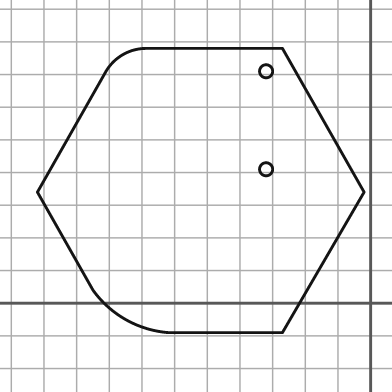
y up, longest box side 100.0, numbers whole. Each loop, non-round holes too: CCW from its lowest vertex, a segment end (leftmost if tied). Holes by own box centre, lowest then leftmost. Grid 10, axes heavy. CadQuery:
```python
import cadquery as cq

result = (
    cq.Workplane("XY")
    .moveTo(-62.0, -9.0)
    .lineTo(-27.0, -9.0)
    .lineTo(-2.0, 34.0)
    .lineTo(-27.0, 78.0)
    .lineTo(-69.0, 78.0)
    .threePointArc((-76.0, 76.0), (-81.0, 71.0))
    .lineTo(-102.0, 34.0)
    .lineTo(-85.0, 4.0)
    .threePointArc((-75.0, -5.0), (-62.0, -9.0))
    .close()
    .moveTo(-32.0, 41.0)
    .circle(2.0)
    .moveTo(-32.0, 71.0)
    .circle(2.0)
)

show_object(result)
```